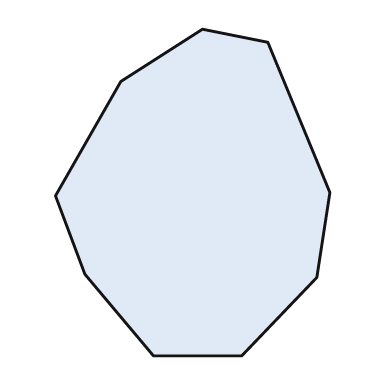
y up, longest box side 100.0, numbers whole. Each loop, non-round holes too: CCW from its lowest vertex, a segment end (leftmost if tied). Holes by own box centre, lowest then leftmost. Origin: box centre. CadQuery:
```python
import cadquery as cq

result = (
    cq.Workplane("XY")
    .moveTo(-12.0, -50.0)
    .lineTo(15.0, -50.0)
    .lineTo(38.0, -26.0)
    .lineTo(42.0, 0.0)
    .lineTo(23.0, 46.0)
    .lineTo(3.0, 50.0)
    .lineTo(-22.0, 34.0)
    .lineTo(-42.0, -1.0)
    .lineTo(-33.0, -25.0)
    .close()
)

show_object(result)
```